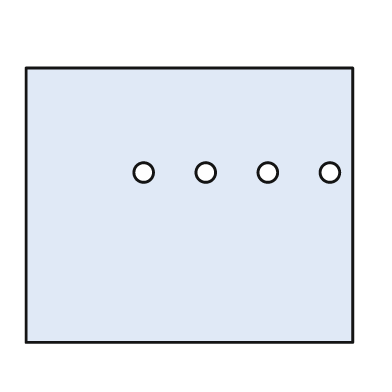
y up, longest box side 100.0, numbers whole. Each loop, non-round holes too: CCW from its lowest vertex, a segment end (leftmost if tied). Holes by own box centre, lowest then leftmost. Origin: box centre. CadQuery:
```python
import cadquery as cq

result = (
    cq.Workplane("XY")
    .moveTo(-50.0, -42.0)
    .lineTo(50.0, -42.0)
    .lineTo(50.0, 42.0)
    .lineTo(-50.0, 42.0)
    .close()
    .moveTo(-14.0, 10.0)
    .circle(3.0)
    .moveTo(5.0, 10.0)
    .circle(3.0)
    .moveTo(24.0, 10.0)
    .circle(3.0)
    .moveTo(43.0, 10.0)
    .circle(3.0)
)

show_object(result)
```